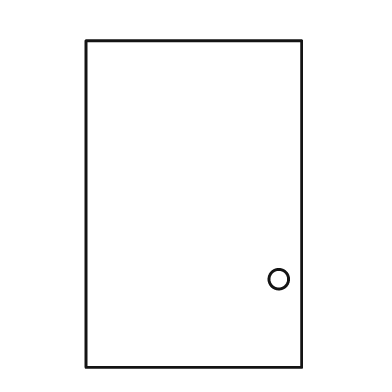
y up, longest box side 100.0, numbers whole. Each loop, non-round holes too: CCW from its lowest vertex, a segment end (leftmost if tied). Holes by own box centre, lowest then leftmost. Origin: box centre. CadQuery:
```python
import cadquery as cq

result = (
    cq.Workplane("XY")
    .moveTo(-33.0, -50.0)
    .lineTo(33.0, -50.0)
    .lineTo(33.0, 50.0)
    .lineTo(-33.0, 50.0)
    .close()
    .moveTo(26.0, -23.0)
    .circle(3.0)
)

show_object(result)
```